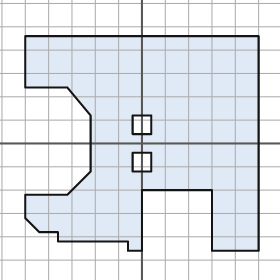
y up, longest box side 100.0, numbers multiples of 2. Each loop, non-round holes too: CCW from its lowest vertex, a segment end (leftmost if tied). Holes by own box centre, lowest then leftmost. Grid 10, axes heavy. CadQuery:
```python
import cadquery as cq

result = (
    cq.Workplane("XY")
    .moveTo(-6.0, -46.0)
    .lineTo(0.0, -46.0)
    .lineTo(0.0, -20.0)
    .lineTo(30.0, -20.0)
    .lineTo(30.0, -46.0)
    .lineTo(50.0, -46.0)
    .lineTo(50.0, 46.0)
    .lineTo(-50.0, 46.0)
    .lineTo(-50.0, 24.0)
    .lineTo(-32.0, 24.0)
    .lineTo(-22.0, 12.0)
    .lineTo(-22.0, -12.0)
    .lineTo(-32.0, -22.0)
    .lineTo(-50.0, -22.0)
    .lineTo(-50.0, -32.0)
    .lineTo(-44.0, -38.0)
    .lineTo(-36.0, -38.0)
    .lineTo(-36.0, -42.0)
    .lineTo(-6.0, -42.0)
    .close()
    .moveTo(-4.0, -12.0)
    .lineTo(4.0, -12.0)
    .lineTo(4.0, -4.0)
    .lineTo(-4.0, -4.0)
    .close()
    .moveTo(-4.0, 4.0)
    .lineTo(4.0, 4.0)
    .lineTo(4.0, 12.0)
    .lineTo(-4.0, 12.0)
    .close()
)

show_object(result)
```